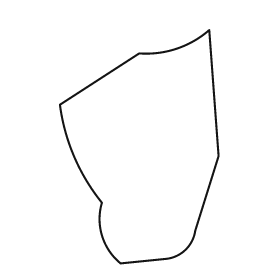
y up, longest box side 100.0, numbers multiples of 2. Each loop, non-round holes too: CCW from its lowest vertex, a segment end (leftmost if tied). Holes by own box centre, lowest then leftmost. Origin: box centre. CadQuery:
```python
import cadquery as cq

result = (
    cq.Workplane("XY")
    .moveTo(-8.0, -50.0)
    .lineTo(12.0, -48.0)
    .threePointArc((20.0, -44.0), (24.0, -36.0))
    .lineTo(34.0, -4.0)
    .lineTo(30.0, 50.0)
    .threePointArc((16.0, 42.0), (0.0, 40.0))
    .lineTo(-34.0, 18.0)
    .threePointArc((-28.0, -4.0), (-16.0, -24.0))
    .threePointArc((-16.0, -38.0), (-8.0, -50.0))
    .close()
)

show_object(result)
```